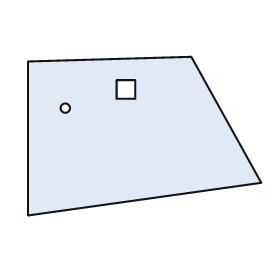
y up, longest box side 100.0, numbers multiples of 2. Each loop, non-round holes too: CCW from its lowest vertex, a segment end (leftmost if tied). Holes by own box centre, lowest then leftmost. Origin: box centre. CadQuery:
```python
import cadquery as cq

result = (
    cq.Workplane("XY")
    .moveTo(-50.0, -34.0)
    .lineTo(50.0, -20.0)
    .lineTo(20.0, 34.0)
    .lineTo(-50.0, 32.0)
    .close()
    .moveTo(-34.0, 12.0)
    .circle(2.0)
    .moveTo(-12.0, 16.0)
    .lineTo(-4.0, 16.0)
    .lineTo(-4.0, 24.0)
    .lineTo(-12.0, 24.0)
    .close()
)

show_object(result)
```